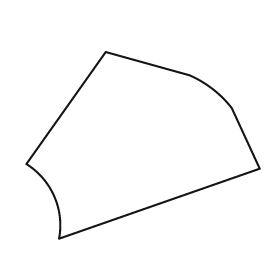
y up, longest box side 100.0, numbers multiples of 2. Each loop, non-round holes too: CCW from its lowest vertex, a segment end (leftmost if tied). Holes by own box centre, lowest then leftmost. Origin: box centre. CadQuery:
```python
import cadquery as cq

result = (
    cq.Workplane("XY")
    .moveTo(-36.0, -40.0)
    .lineTo(50.0, -10.0)
    .lineTo(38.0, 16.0)
    .threePointArc((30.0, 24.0), (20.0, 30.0))
    .lineTo(-16.0, 40.0)
    .lineTo(-50.0, -8.0)
    .threePointArc((-38.0, -22.0), (-36.0, -40.0))
    .close()
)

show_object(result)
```